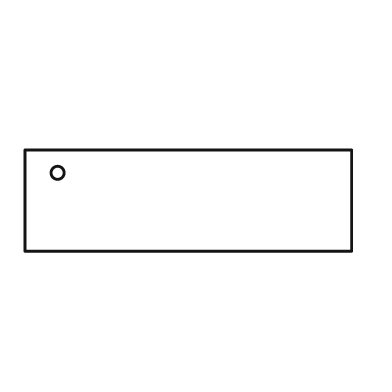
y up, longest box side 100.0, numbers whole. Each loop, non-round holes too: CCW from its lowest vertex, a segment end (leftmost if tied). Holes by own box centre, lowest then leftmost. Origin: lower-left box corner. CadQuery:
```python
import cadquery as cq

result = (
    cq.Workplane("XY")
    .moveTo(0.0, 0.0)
    .lineTo(100.0, 0.0)
    .lineTo(100.0, 31.0)
    .lineTo(0.0, 31.0)
    .close()
    .moveTo(10.0, 24.0)
    .circle(2.0)
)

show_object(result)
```